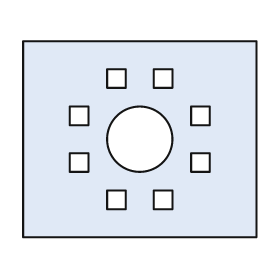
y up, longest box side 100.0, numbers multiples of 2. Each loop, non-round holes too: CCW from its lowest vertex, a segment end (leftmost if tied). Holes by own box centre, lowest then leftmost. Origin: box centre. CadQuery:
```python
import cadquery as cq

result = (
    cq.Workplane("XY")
    .moveTo(-50.0, -42.0)
    .lineTo(50.0, -42.0)
    .lineTo(50.0, 42.0)
    .lineTo(-50.0, 42.0)
    .close()
    .moveTo(-14.0, -30.0)
    .lineTo(-6.0, -30.0)
    .lineTo(-6.0, -22.0)
    .lineTo(-14.0, -22.0)
    .close()
    .moveTo(6.0, -30.0)
    .lineTo(14.0, -30.0)
    .lineTo(14.0, -22.0)
    .lineTo(6.0, -22.0)
    .close()
    .moveTo(-30.0, -14.0)
    .lineTo(-22.0, -14.0)
    .lineTo(-22.0, -6.0)
    .lineTo(-30.0, -6.0)
    .close()
    .moveTo(22.0, -14.0)
    .lineTo(30.0, -14.0)
    .lineTo(30.0, -6.0)
    .lineTo(22.0, -6.0)
    .close()
    .moveTo(0.0, 0.0)
    .circle(14.0)
    .moveTo(-30.0, 6.0)
    .lineTo(-22.0, 6.0)
    .lineTo(-22.0, 14.0)
    .lineTo(-30.0, 14.0)
    .close()
    .moveTo(22.0, 6.0)
    .lineTo(30.0, 6.0)
    .lineTo(30.0, 14.0)
    .lineTo(22.0, 14.0)
    .close()
    .moveTo(-14.0, 22.0)
    .lineTo(-6.0, 22.0)
    .lineTo(-6.0, 30.0)
    .lineTo(-14.0, 30.0)
    .close()
    .moveTo(6.0, 22.0)
    .lineTo(14.0, 22.0)
    .lineTo(14.0, 30.0)
    .lineTo(6.0, 30.0)
    .close()
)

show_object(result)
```